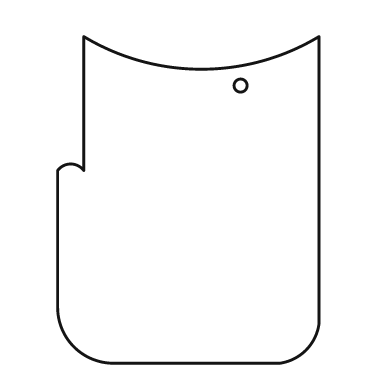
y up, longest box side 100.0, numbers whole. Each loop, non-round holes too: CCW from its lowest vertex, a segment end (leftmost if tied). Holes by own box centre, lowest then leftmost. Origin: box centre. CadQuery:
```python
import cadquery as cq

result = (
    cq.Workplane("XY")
    .moveTo(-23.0, -50.0)
    .lineTo(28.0, -50.0)
    .threePointArc((36.0, -46.0), (40.0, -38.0))
    .lineTo(40.0, 50.0)
    .threePointArc((4.0, 40.0), (-32.0, 50.0))
    .lineTo(-32.0, 9.0)
    .threePointArc((-36.0, 11.0), (-40.0, 9.0))
    .lineTo(-40.0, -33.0)
    .threePointArc((-35.0, -45.0), (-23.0, -50.0))
    .close()
    .moveTo(16.0, 35.0)
    .circle(2.0)
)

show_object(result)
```